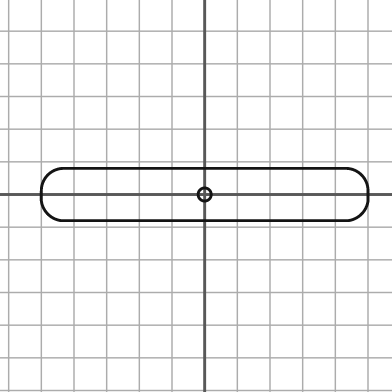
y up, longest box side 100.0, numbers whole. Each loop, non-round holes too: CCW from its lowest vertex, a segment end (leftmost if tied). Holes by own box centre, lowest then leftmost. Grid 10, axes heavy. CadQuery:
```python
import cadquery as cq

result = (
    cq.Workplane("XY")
    .moveTo(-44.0, -8.0)
    .lineTo(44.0, -8.0)
    .threePointArc((48.0, -6.0), (50.0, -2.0))
    .lineTo(50.0, 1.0)
    .threePointArc((48.0, 6.0), (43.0, 8.0))
    .lineTo(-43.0, 8.0)
    .threePointArc((-48.0, 6.0), (-50.0, 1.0))
    .lineTo(-50.0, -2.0)
    .threePointArc((-48.0, -6.0), (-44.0, -8.0))
    .close()
    .moveTo(0.0, 0.0)
    .circle(2.0)
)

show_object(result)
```